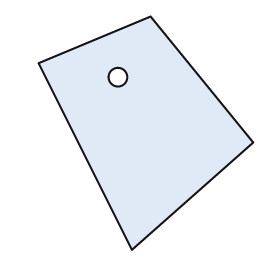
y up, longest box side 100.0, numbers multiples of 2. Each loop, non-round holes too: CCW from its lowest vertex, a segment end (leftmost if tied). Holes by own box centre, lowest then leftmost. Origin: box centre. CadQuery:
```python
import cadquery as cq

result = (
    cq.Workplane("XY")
    .moveTo(-6.0, -50.0)
    .lineTo(46.0, -4.0)
    .lineTo(2.0, 50.0)
    .lineTo(-46.0, 30.0)
    .close()
    .moveTo(-12.0, 24.0)
    .circle(4.0)
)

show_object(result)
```